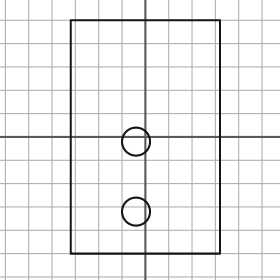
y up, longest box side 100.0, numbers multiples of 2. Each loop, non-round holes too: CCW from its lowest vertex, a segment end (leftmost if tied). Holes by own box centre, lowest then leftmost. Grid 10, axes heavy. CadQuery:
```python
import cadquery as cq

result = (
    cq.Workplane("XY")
    .moveTo(-32.0, -50.0)
    .lineTo(32.0, -50.0)
    .lineTo(32.0, 50.0)
    .lineTo(-32.0, 50.0)
    .close()
    .moveTo(-4.0, -32.0)
    .circle(6.0)
    .moveTo(-4.0, -2.0)
    .circle(6.0)
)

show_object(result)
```